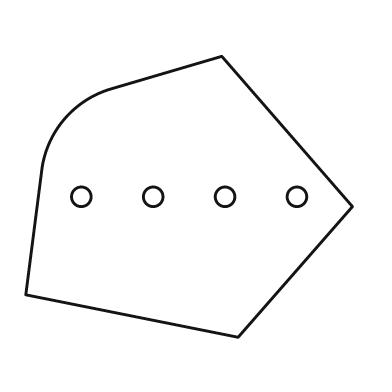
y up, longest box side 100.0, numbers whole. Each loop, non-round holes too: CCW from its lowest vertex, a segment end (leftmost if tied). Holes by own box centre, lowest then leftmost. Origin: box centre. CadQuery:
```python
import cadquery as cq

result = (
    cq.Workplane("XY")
    .moveTo(15.0, -43.0)
    .lineTo(50.0, -3.0)
    .lineTo(10.0, 43.0)
    .lineTo(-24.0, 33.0)
    .threePointArc((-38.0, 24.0), (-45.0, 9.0))
    .lineTo(-50.0, -30.0)
    .close()
    .moveTo(-33.0, 0.0)
    .circle(3.0)
    .moveTo(-11.0, 0.0)
    .circle(3.0)
    .moveTo(11.0, 0.0)
    .circle(3.0)
    .moveTo(33.0, 0.0)
    .circle(3.0)
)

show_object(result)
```